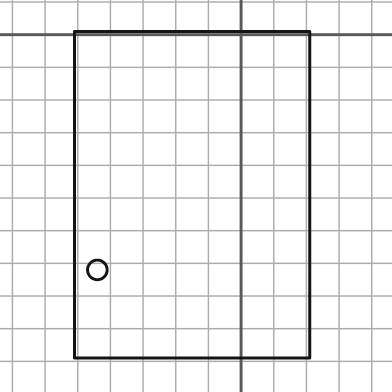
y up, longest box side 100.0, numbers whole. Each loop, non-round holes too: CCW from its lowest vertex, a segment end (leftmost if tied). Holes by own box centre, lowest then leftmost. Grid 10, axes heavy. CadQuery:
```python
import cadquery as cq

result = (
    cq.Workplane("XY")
    .moveTo(-51.0, -99.0)
    .lineTo(21.0, -99.0)
    .lineTo(21.0, 1.0)
    .lineTo(-51.0, 1.0)
    .close()
    .moveTo(-44.0, -72.0)
    .circle(3.0)
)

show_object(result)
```